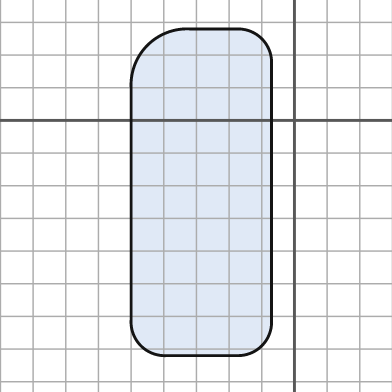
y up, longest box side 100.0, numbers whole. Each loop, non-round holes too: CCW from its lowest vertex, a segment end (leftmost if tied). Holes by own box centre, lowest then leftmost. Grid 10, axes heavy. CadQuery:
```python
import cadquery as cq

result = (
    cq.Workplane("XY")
    .moveTo(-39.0, -72.0)
    .lineTo(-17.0, -72.0)
    .threePointArc((-10.0, -69.0), (-7.0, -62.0))
    .lineTo(-7.0, 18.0)
    .threePointArc((-10.0, 25.0), (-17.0, 28.0))
    .lineTo(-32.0, 28.0)
    .threePointArc((-45.0, 23.0), (-50.0, 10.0))
    .lineTo(-50.0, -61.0)
    .threePointArc((-47.0, -69.0), (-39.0, -72.0))
    .close()
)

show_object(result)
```